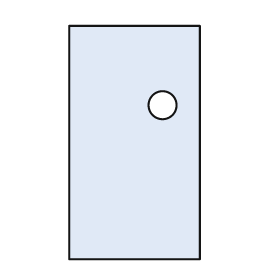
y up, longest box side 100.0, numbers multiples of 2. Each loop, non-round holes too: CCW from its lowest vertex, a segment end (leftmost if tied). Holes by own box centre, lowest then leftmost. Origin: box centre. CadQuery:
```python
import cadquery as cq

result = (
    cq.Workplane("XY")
    .moveTo(-28.0, -50.0)
    .lineTo(28.0, -50.0)
    .lineTo(28.0, 50.0)
    .lineTo(-28.0, 50.0)
    .close()
    .moveTo(12.0, 16.0)
    .circle(6.0)
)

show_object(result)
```